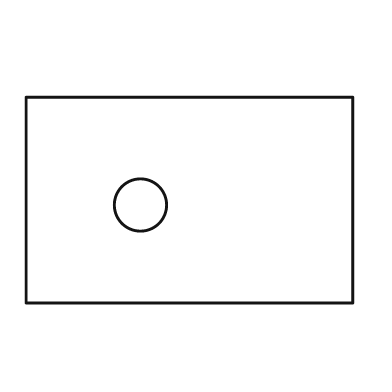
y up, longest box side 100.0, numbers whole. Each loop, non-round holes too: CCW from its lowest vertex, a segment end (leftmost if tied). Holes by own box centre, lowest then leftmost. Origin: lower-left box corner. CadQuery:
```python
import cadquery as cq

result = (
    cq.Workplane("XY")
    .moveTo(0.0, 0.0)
    .lineTo(100.0, 0.0)
    .lineTo(100.0, 63.0)
    .lineTo(0.0, 63.0)
    .close()
    .moveTo(35.0, 30.0)
    .circle(8.0)
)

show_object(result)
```